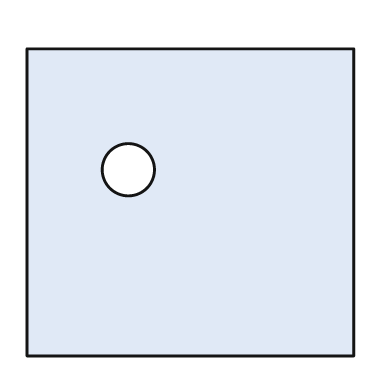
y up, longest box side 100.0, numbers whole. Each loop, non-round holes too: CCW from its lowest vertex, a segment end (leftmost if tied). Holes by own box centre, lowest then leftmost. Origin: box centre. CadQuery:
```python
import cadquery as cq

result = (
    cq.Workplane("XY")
    .moveTo(-50.0, -47.0)
    .lineTo(50.0, -47.0)
    .lineTo(50.0, 47.0)
    .lineTo(-50.0, 47.0)
    .close()
    .moveTo(-19.0, 10.0)
    .circle(8.0)
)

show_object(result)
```